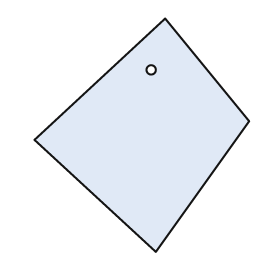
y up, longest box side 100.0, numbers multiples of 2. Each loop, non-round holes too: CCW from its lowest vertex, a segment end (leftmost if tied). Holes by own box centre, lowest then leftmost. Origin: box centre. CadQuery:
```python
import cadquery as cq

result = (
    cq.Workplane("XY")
    .moveTo(6.0, -50.0)
    .lineTo(46.0, 6.0)
    .lineTo(10.0, 50.0)
    .lineTo(-46.0, -2.0)
    .close()
    .moveTo(4.0, 28.0)
    .circle(2.0)
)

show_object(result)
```